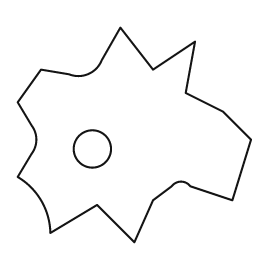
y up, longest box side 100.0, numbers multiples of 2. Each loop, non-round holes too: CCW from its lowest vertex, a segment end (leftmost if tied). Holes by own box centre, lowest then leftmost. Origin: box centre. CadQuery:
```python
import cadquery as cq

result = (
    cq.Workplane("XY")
    .moveTo(0.0, -46.0)
    .lineTo(8.0, -28.0)
    .lineTo(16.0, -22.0)
    .threePointArc((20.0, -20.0), (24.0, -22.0))
    .lineTo(42.0, -28.0)
    .lineTo(50.0, -2.0)
    .lineTo(38.0, 10.0)
    .lineTo(22.0, 18.0)
    .lineTo(26.0, 40.0)
    .lineTo(8.0, 28.0)
    .lineTo(-6.0, 46.0)
    .lineTo(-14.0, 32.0)
    .threePointArc((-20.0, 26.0), (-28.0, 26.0))
    .lineTo(-40.0, 28.0)
    .lineTo(-50.0, 14.0)
    .lineTo(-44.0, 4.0)
    .threePointArc((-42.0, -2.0), (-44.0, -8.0))
    .lineTo(-50.0, -18.0)
    .threePointArc((-40.0, -28.0), (-36.0, -42.0))
    .lineTo(-16.0, -30.0)
    .close()
    .moveTo(-18.0, -6.0)
    .circle(8.0)
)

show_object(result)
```